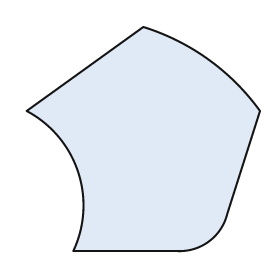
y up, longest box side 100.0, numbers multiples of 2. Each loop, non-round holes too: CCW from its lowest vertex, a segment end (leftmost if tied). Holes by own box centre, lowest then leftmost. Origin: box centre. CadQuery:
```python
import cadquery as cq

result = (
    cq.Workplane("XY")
    .moveTo(-30.0, -48.0)
    .lineTo(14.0, -48.0)
    .threePointArc((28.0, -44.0), (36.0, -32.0))
    .lineTo(50.0, 12.0)
    .threePointArc((28.0, 34.0), (0.0, 48.0))
    .lineTo(-50.0, 12.0)
    .threePointArc((-28.0, -14.0), (-30.0, -48.0))
    .close()
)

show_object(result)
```